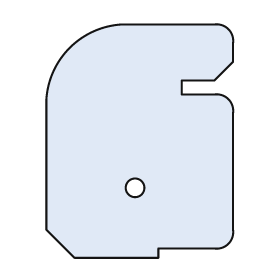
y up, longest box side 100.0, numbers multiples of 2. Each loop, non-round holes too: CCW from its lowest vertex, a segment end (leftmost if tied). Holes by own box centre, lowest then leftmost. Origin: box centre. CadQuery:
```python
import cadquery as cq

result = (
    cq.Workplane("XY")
    .moveTo(-28.0, -50.0)
    .lineTo(8.0, -50.0)
    .lineTo(8.0, -46.0)
    .lineTo(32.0, -46.0)
    .threePointArc((38.0, -44.0), (40.0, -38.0))
    .lineTo(40.0, 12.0)
    .threePointArc((38.0, 18.0), (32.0, 20.0))
    .lineTo(18.0, 20.0)
    .lineTo(18.0, 26.0)
    .lineTo(32.0, 26.0)
    .lineTo(40.0, 34.0)
    .lineTo(40.0, 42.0)
    .threePointArc((38.0, 48.0), (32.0, 50.0))
    .lineTo(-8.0, 50.0)
    .threePointArc((-30.0, 40.0), (-40.0, 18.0))
    .lineTo(-40.0, -38.0)
    .close()
    .moveTo(-2.0, -20.0)
    .circle(4.0)
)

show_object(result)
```